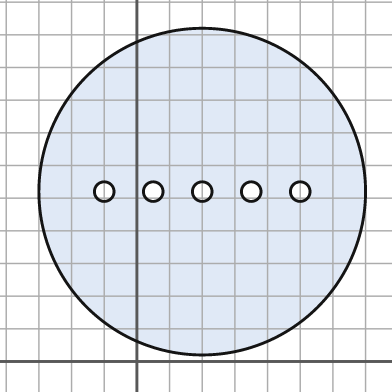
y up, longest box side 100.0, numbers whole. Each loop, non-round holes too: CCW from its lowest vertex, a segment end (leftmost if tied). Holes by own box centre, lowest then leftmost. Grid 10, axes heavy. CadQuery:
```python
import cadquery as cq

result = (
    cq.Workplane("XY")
    .moveTo(20.0, 52.0)
    .circle(50.0)
    .moveTo(-10.0, 52.0)
    .circle(3.0)
    .moveTo(5.0, 52.0)
    .circle(3.0)
    .moveTo(20.0, 52.0)
    .circle(3.0)
    .moveTo(35.0, 52.0)
    .circle(3.0)
    .moveTo(50.0, 52.0)
    .circle(3.0)
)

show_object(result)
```